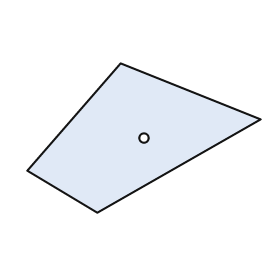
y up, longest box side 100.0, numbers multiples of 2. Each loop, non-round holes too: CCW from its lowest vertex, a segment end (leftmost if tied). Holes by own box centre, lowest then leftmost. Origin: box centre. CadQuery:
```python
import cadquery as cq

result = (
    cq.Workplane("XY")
    .moveTo(-20.0, -32.0)
    .lineTo(50.0, 8.0)
    .lineTo(-10.0, 32.0)
    .lineTo(-50.0, -14.0)
    .close()
    .moveTo(0.0, 0.0)
    .circle(2.0)
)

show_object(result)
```